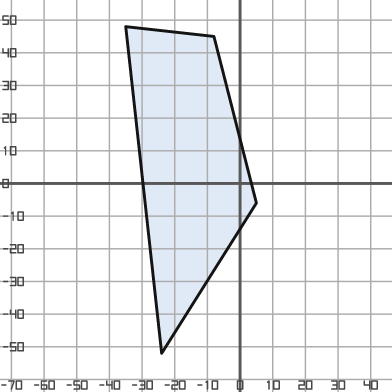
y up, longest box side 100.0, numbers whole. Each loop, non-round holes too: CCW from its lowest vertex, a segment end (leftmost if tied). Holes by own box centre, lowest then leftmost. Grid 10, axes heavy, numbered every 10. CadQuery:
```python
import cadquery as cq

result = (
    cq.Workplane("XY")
    .moveTo(-24.0, -52.0)
    .lineTo(5.0, -6.0)
    .lineTo(-8.0, 45.0)
    .lineTo(-35.0, 48.0)
    .close()
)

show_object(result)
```